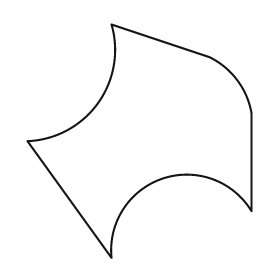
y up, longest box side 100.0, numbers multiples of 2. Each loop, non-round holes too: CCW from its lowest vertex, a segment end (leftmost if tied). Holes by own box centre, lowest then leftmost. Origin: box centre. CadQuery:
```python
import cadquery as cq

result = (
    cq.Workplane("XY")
    .moveTo(-12.0, -50.0)
    .threePointArc((10.0, -16.0), (48.0, -30.0))
    .lineTo(48.0, 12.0)
    .threePointArc((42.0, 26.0), (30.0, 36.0))
    .lineTo(-12.0, 50.0)
    .threePointArc((-18.0, 16.0), (-48.0, 0.0))
    .close()
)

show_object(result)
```